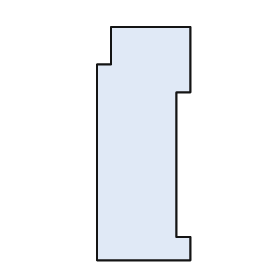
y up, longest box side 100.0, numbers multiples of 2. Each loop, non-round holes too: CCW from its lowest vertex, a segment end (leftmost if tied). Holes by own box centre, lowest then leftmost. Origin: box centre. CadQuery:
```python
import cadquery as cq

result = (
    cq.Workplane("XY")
    .moveTo(-20.0, -50.0)
    .lineTo(20.0, -50.0)
    .lineTo(20.0, -40.0)
    .lineTo(14.0, -40.0)
    .lineTo(14.0, 22.0)
    .lineTo(20.0, 22.0)
    .lineTo(20.0, 50.0)
    .lineTo(-14.0, 50.0)
    .lineTo(-14.0, 34.0)
    .lineTo(-20.0, 34.0)
    .close()
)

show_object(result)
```